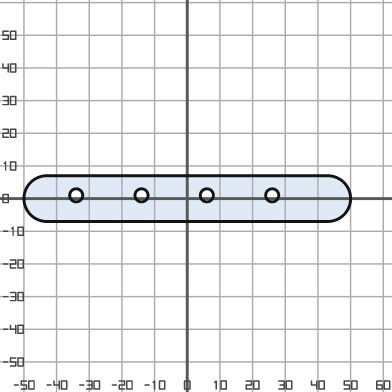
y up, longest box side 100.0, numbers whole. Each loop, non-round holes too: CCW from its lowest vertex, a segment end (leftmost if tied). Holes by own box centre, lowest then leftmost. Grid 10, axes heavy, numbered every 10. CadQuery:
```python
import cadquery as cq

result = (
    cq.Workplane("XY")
    .moveTo(-43.0, -7.0)
    .lineTo(43.0, -7.0)
    .threePointArc((50.0, 0.0), (43.0, 7.0))
    .lineTo(-43.0, 7.0)
    .threePointArc((-50.0, 0.0), (-43.0, -7.0))
    .close()
    .moveTo(-34.0, 1.0)
    .circle(2.0)
    .moveTo(-14.0, 1.0)
    .circle(2.0)
    .moveTo(6.0, 1.0)
    .circle(2.0)
    .moveTo(26.0, 1.0)
    .circle(2.0)
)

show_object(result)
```